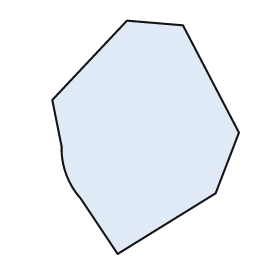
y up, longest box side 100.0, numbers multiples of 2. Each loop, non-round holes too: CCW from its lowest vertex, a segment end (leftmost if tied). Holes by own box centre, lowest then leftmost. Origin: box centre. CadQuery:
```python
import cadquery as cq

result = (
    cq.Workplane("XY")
    .moveTo(-12.0, -50.0)
    .lineTo(30.0, -24.0)
    .lineTo(40.0, 2.0)
    .lineTo(16.0, 48.0)
    .lineTo(-8.0, 50.0)
    .lineTo(-40.0, 16.0)
    .lineTo(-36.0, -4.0)
    .threePointArc((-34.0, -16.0), (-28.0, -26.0))
    .close()
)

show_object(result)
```